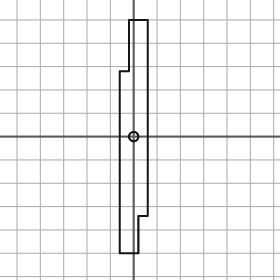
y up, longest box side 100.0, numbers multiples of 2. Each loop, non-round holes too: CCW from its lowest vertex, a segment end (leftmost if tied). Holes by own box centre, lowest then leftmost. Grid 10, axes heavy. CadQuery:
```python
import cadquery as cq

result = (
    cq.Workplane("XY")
    .moveTo(-6.0, -50.0)
    .lineTo(2.0, -50.0)
    .lineTo(2.0, -34.0)
    .lineTo(6.0, -34.0)
    .lineTo(6.0, 50.0)
    .lineTo(-2.0, 50.0)
    .lineTo(-2.0, 28.0)
    .lineTo(-6.0, 28.0)
    .close()
    .moveTo(0.0, 0.0)
    .circle(2.0)
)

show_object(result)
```